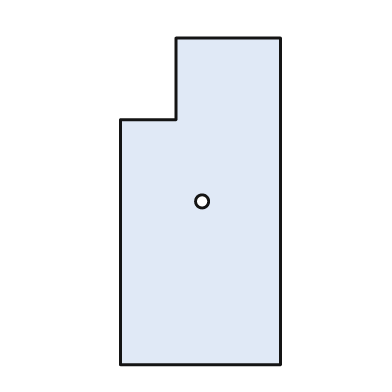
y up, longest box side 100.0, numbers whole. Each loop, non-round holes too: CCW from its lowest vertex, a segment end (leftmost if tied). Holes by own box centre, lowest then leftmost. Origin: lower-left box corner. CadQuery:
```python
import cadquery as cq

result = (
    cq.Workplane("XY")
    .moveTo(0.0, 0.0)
    .lineTo(49.0, 0.0)
    .lineTo(49.0, 100.0)
    .lineTo(17.0, 100.0)
    .lineTo(17.0, 75.0)
    .lineTo(0.0, 75.0)
    .close()
    .moveTo(25.0, 50.0)
    .circle(2.0)
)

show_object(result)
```